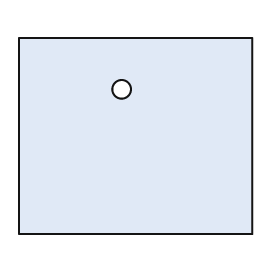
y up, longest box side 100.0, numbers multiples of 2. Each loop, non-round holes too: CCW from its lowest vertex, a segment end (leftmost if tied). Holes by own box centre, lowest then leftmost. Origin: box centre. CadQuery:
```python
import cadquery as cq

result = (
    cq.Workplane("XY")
    .moveTo(-50.0, -42.0)
    .lineTo(50.0, -42.0)
    .lineTo(50.0, 42.0)
    .lineTo(-50.0, 42.0)
    .close()
    .moveTo(-6.0, 20.0)
    .circle(4.0)
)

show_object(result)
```